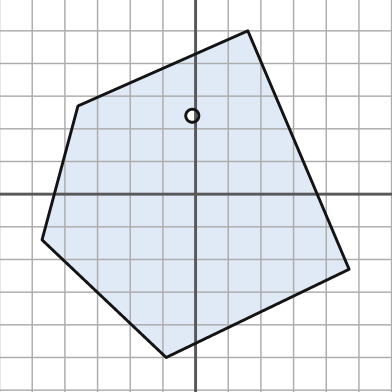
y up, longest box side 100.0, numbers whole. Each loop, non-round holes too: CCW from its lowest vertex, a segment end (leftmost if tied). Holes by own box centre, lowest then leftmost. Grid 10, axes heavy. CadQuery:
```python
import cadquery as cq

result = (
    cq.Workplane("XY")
    .moveTo(-9.0, -50.0)
    .lineTo(47.0, -23.0)
    .lineTo(16.0, 50.0)
    .lineTo(-36.0, 27.0)
    .lineTo(-47.0, -14.0)
    .close()
    .moveTo(-1.0, 24.0)
    .circle(2.0)
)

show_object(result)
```